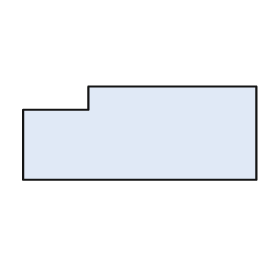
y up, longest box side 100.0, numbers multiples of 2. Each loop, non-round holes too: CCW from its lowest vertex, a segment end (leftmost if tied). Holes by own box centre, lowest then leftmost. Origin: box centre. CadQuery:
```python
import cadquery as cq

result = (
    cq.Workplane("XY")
    .moveTo(-50.0, -20.0)
    .lineTo(50.0, -20.0)
    .lineTo(50.0, 20.0)
    .lineTo(-22.0, 20.0)
    .lineTo(-22.0, 10.0)
    .lineTo(-50.0, 10.0)
    .close()
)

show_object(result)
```